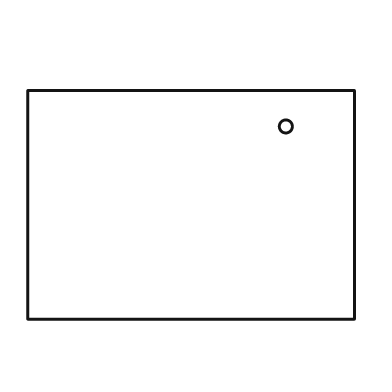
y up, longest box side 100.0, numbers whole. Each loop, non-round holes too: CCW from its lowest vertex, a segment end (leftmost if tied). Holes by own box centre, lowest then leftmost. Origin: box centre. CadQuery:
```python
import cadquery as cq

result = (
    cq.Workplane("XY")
    .moveTo(-50.0, -35.0)
    .lineTo(50.0, -35.0)
    .lineTo(50.0, 35.0)
    .lineTo(-50.0, 35.0)
    .close()
    .moveTo(29.0, 24.0)
    .circle(2.0)
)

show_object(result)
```